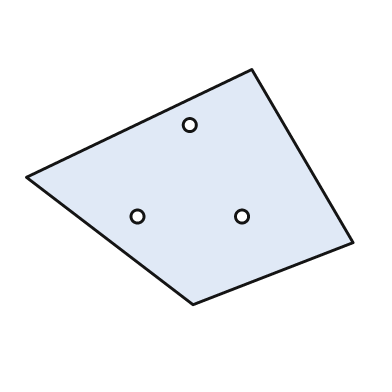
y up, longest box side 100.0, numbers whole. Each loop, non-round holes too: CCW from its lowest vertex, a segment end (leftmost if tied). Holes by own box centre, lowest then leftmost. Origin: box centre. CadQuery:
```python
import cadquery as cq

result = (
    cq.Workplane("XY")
    .moveTo(1.0, -36.0)
    .lineTo(50.0, -17.0)
    .lineTo(19.0, 36.0)
    .lineTo(-50.0, 3.0)
    .close()
    .moveTo(-16.0, -9.0)
    .circle(2.0)
    .moveTo(16.0, -9.0)
    .circle(2.0)
    .moveTo(0.0, 19.0)
    .circle(2.0)
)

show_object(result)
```